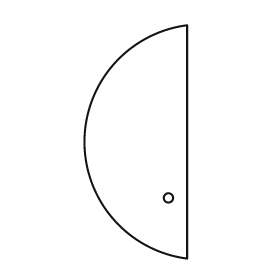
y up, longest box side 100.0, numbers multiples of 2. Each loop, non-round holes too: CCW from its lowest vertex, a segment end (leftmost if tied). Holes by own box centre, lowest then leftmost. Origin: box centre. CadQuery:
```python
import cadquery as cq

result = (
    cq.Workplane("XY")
    .moveTo(22.0, -50.0)
    .lineTo(22.0, 50.0)
    .threePointArc((-22.0, 0.0), (22.0, -50.0))
    .close()
    .moveTo(14.0, -24.0)
    .circle(2.0)
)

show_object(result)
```